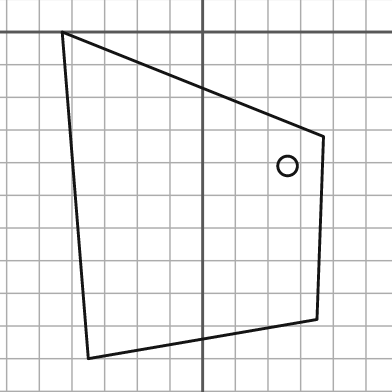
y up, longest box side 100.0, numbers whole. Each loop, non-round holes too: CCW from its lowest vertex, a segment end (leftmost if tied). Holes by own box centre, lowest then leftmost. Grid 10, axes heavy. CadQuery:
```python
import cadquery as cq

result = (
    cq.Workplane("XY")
    .moveTo(-35.0, -100.0)
    .lineTo(35.0, -88.0)
    .lineTo(37.0, -32.0)
    .lineTo(-43.0, 0.0)
    .close()
    .moveTo(26.0, -41.0)
    .circle(3.0)
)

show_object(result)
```